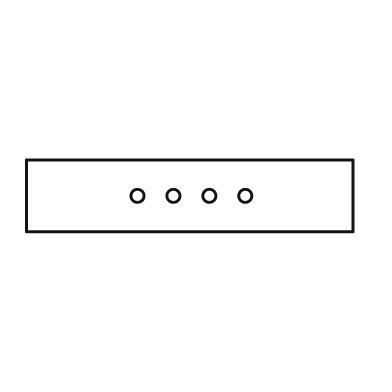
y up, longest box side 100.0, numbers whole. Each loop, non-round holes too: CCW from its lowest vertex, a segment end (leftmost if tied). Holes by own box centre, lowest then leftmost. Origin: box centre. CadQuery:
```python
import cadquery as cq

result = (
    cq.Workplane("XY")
    .moveTo(-50.0, -11.0)
    .lineTo(50.0, -11.0)
    .lineTo(50.0, 11.0)
    .lineTo(-50.0, 11.0)
    .close()
    .moveTo(-16.0, 0.0)
    .circle(2.0)
    .moveTo(-5.0, 0.0)
    .circle(2.0)
    .moveTo(6.0, 0.0)
    .circle(2.0)
    .moveTo(17.0, 0.0)
    .circle(2.0)
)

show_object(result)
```